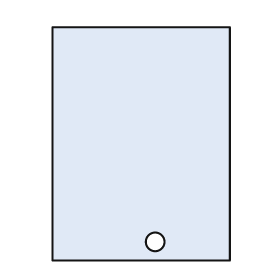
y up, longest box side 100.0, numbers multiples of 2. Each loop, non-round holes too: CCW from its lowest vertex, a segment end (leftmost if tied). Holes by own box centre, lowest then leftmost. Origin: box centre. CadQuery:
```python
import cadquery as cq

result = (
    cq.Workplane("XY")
    .moveTo(-38.0, -50.0)
    .lineTo(38.0, -50.0)
    .lineTo(38.0, 50.0)
    .lineTo(-38.0, 50.0)
    .close()
    .moveTo(6.0, -42.0)
    .circle(4.0)
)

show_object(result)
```